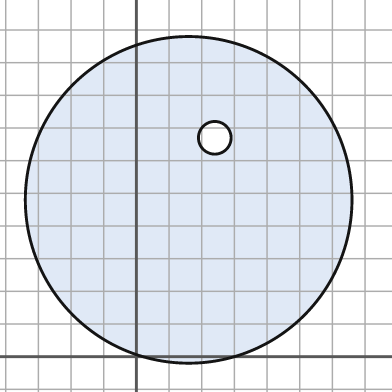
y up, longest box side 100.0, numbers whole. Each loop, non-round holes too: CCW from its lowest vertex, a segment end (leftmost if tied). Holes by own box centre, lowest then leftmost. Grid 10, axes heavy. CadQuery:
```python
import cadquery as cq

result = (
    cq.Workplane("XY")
    .moveTo(16.0, 48.0)
    .circle(50.0)
    .moveTo(24.0, 67.0)
    .circle(5.0)
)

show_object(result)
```